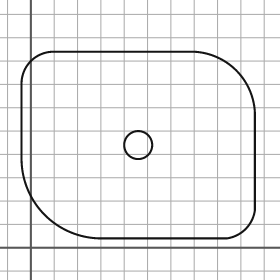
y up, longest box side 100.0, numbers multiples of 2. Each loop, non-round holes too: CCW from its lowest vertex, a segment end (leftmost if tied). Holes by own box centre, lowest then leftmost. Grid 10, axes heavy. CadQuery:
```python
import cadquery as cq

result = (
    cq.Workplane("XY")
    .moveTo(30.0, 4.0)
    .lineTo(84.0, 4.0)
    .threePointArc((92.0, 8.0), (96.0, 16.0))
    .lineTo(96.0, 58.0)
    .threePointArc((88.0, 76.0), (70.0, 84.0))
    .lineTo(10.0, 84.0)
    .threePointArc((0.0, 80.0), (-4.0, 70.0))
    .lineTo(-4.0, 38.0)
    .threePointArc((6.0, 14.0), (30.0, 4.0))
    .close()
    .moveTo(46.0, 44.0)
    .circle(6.0)
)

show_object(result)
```